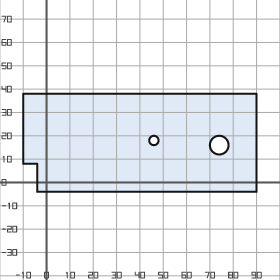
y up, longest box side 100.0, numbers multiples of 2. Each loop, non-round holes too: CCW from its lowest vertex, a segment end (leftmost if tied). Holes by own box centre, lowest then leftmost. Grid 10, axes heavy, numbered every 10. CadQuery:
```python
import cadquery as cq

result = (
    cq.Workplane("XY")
    .moveTo(-4.0, -4.0)
    .lineTo(90.0, -4.0)
    .lineTo(90.0, 38.0)
    .lineTo(-10.0, 38.0)
    .lineTo(-10.0, 8.0)
    .lineTo(-4.0, 8.0)
    .close()
    .moveTo(74.0, 16.0)
    .circle(4.0)
    .moveTo(46.0, 18.0)
    .circle(2.0)
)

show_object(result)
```